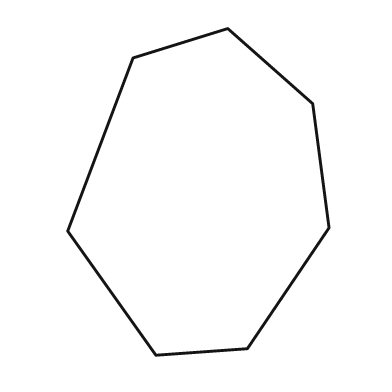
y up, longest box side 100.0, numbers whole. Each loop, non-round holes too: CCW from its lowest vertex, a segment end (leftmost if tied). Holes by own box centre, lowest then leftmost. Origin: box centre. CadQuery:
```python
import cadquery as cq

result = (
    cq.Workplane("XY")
    .moveTo(-13.0, -50.0)
    .lineTo(15.0, -48.0)
    .lineTo(40.0, -11.0)
    .lineTo(35.0, 27.0)
    .lineTo(9.0, 50.0)
    .lineTo(-20.0, 41.0)
    .lineTo(-40.0, -12.0)
    .close()
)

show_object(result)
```